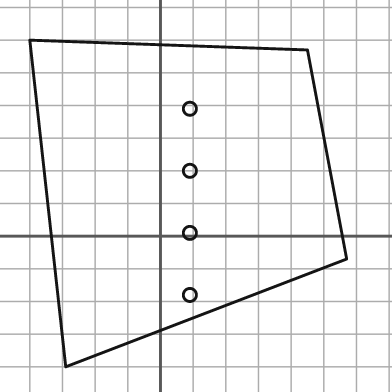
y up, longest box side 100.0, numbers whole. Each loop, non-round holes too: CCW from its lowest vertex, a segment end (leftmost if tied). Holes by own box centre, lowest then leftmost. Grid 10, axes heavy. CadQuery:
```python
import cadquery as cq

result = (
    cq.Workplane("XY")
    .moveTo(-29.0, -40.0)
    .lineTo(57.0, -7.0)
    .lineTo(45.0, 57.0)
    .lineTo(-40.0, 60.0)
    .close()
    .moveTo(9.0, -18.0)
    .circle(2.0)
    .moveTo(9.0, 1.0)
    .circle(2.0)
    .moveTo(9.0, 20.0)
    .circle(2.0)
    .moveTo(9.0, 39.0)
    .circle(2.0)
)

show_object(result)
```